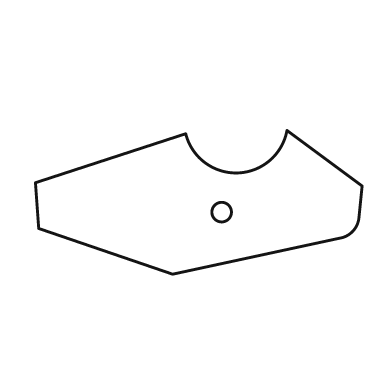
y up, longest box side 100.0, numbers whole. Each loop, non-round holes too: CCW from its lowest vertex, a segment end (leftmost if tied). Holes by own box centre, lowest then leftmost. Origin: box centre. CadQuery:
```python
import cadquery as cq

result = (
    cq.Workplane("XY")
    .moveTo(-8.0, -22.0)
    .lineTo(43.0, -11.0)
    .threePointArc((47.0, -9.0), (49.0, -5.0))
    .lineTo(50.0, 5.0)
    .lineTo(27.0, 22.0)
    .threePointArc((12.0, 9.0), (-4.0, 21.0))
    .lineTo(-50.0, 6.0)
    .lineTo(-49.0, -8.0)
    .close()
    .moveTo(7.0, -3.0)
    .circle(3.0)
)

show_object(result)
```